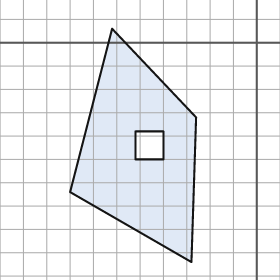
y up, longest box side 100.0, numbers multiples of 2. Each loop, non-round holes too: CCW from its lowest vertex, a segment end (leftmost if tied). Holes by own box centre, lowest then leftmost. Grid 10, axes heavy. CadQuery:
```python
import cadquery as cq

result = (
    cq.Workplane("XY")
    .moveTo(-28.0, -94.0)
    .lineTo(-26.0, -32.0)
    .lineTo(-62.0, 6.0)
    .lineTo(-80.0, -64.0)
    .close()
    .moveTo(-52.0, -50.0)
    .lineTo(-40.0, -50.0)
    .lineTo(-40.0, -38.0)
    .lineTo(-52.0, -38.0)
    .close()
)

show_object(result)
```